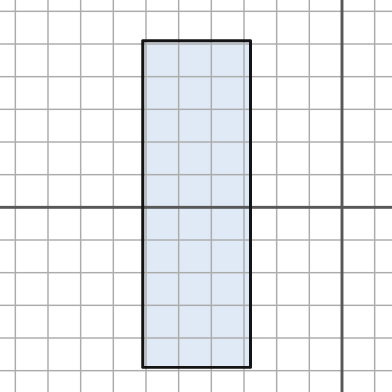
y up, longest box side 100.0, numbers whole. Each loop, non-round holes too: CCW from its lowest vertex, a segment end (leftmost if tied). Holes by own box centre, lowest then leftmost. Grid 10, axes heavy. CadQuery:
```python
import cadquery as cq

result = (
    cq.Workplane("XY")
    .moveTo(-61.0, -49.0)
    .lineTo(-28.0, -49.0)
    .lineTo(-28.0, 51.0)
    .lineTo(-61.0, 51.0)
    .close()
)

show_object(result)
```